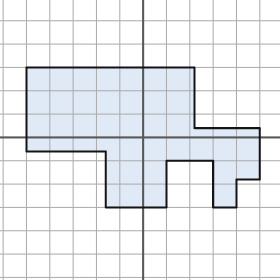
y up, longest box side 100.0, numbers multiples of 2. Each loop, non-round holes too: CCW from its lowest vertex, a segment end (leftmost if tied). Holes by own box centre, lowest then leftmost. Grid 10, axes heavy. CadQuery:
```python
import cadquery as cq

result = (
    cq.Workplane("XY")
    .moveTo(-16.0, -30.0)
    .lineTo(10.0, -30.0)
    .lineTo(10.0, -10.0)
    .lineTo(30.0, -10.0)
    .lineTo(30.0, -30.0)
    .lineTo(40.0, -30.0)
    .lineTo(40.0, -18.0)
    .lineTo(50.0, -18.0)
    .lineTo(50.0, 4.0)
    .lineTo(22.0, 4.0)
    .lineTo(22.0, 30.0)
    .lineTo(-50.0, 30.0)
    .lineTo(-50.0, -6.0)
    .lineTo(-16.0, -6.0)
    .close()
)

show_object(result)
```